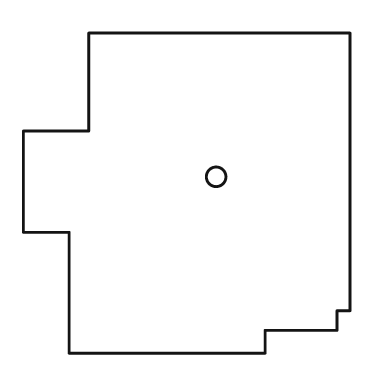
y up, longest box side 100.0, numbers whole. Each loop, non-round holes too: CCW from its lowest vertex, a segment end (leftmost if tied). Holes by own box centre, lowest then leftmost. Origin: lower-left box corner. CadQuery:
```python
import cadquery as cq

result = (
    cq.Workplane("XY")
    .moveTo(14.0, 0.0)
    .lineTo(74.0, 0.0)
    .lineTo(74.0, 7.0)
    .lineTo(96.0, 7.0)
    .lineTo(96.0, 13.0)
    .lineTo(100.0, 13.0)
    .lineTo(100.0, 98.0)
    .lineTo(20.0, 98.0)
    .lineTo(20.0, 68.0)
    .lineTo(0.0, 68.0)
    .lineTo(0.0, 37.0)
    .lineTo(14.0, 37.0)
    .close()
    .moveTo(59.0, 54.0)
    .circle(3.0)
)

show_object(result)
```